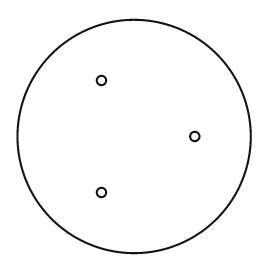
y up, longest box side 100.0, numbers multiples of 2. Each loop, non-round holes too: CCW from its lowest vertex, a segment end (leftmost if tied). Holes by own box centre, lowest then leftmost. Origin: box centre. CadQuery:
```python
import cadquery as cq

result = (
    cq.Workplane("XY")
    .moveTo(0.0, 0.0)
    .circle(50.0)
    .moveTo(-14.0, -24.0)
    .circle(2.0)
    .moveTo(26.0, 0.0)
    .circle(2.0)
    .moveTo(-14.0, 24.0)
    .circle(2.0)
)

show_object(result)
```